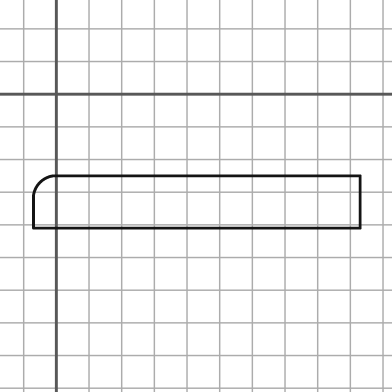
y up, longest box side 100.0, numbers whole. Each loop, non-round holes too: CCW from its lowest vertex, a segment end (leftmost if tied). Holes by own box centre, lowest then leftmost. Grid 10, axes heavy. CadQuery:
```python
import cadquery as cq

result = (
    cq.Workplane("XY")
    .moveTo(-7.0, -41.0)
    .lineTo(93.0, -41.0)
    .lineTo(93.0, -25.0)
    .lineTo(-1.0, -25.0)
    .threePointArc((-5.0, -27.0), (-7.0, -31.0))
    .close()
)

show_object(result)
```